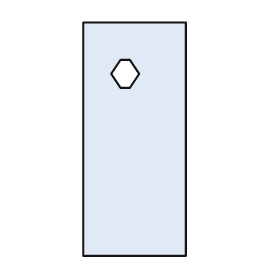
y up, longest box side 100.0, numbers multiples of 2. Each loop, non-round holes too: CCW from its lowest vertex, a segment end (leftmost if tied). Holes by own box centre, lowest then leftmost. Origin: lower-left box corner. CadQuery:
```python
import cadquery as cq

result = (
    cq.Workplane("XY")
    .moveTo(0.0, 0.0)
    .lineTo(44.0, 0.0)
    .lineTo(44.0, 100.0)
    .lineTo(0.0, 100.0)
    .close()
    .moveTo(16.0, 72.0)
    .lineTo(20.0, 72.0)
    .lineTo(24.0, 78.0)
    .lineTo(20.0, 84.0)
    .lineTo(16.0, 84.0)
    .lineTo(12.0, 78.0)
    .close()
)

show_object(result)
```